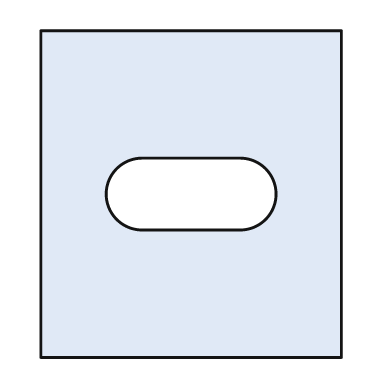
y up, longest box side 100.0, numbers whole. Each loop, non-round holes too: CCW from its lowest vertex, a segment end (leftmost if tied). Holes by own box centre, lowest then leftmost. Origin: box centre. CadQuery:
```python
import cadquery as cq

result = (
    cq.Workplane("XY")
    .moveTo(-46.0, -50.0)
    .lineTo(46.0, -50.0)
    .lineTo(46.0, 50.0)
    .lineTo(-46.0, 50.0)
    .close()
    .moveTo(-15.0, -11.0)
    .lineTo(15.0, -11.0)
    .threePointArc((26.0, 0.0), (15.0, 11.0))
    .lineTo(-15.0, 11.0)
    .threePointArc((-26.0, 0.0), (-15.0, -11.0))
    .close()
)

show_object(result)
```